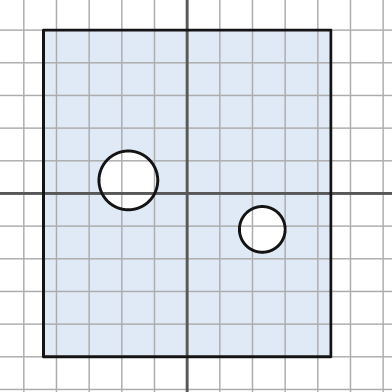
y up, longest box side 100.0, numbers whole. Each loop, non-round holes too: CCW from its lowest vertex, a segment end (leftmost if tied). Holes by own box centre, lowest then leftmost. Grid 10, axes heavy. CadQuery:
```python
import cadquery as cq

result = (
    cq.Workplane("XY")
    .moveTo(-44.0, -50.0)
    .lineTo(44.0, -50.0)
    .lineTo(44.0, 50.0)
    .lineTo(-44.0, 50.0)
    .close()
    .moveTo(23.0, -11.0)
    .circle(7.0)
    .moveTo(-18.0, 4.0)
    .circle(9.0)
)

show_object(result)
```